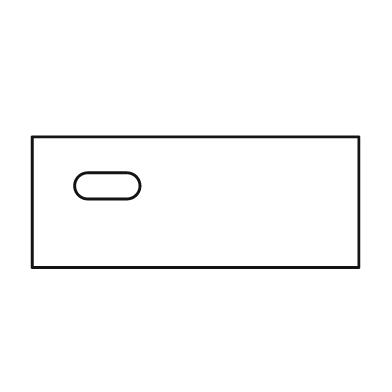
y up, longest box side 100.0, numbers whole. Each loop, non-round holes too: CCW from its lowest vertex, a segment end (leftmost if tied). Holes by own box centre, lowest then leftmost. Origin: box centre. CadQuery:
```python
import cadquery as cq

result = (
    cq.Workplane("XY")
    .moveTo(-50.0, -20.0)
    .lineTo(50.0, -20.0)
    .lineTo(50.0, 20.0)
    .lineTo(-50.0, 20.0)
    .close()
    .moveTo(-33.0, 1.0)
    .lineTo(-21.0, 1.0)
    .threePointArc((-17.0, 5.0), (-21.0, 9.0))
    .lineTo(-33.0, 9.0)
    .threePointArc((-37.0, 5.0), (-33.0, 1.0))
    .close()
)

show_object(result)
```